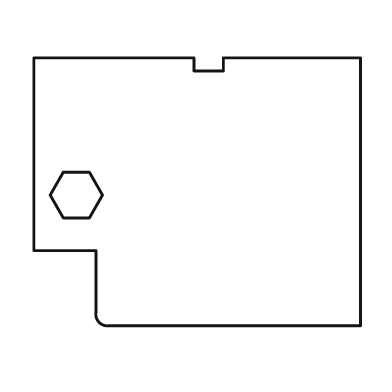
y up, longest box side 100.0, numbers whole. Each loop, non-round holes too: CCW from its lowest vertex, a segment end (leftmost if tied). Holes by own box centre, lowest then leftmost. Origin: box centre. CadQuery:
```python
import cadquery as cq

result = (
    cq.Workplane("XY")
    .moveTo(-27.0, -41.0)
    .lineTo(50.0, -41.0)
    .lineTo(50.0, 41.0)
    .lineTo(8.0, 41.0)
    .lineTo(8.0, 37.0)
    .lineTo(-1.0, 37.0)
    .lineTo(-1.0, 41.0)
    .lineTo(-50.0, 41.0)
    .lineTo(-50.0, -18.0)
    .lineTo(-31.0, -18.0)
    .lineTo(-31.0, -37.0)
    .threePointArc((-30.0, -40.0), (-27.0, -41.0))
    .close()
    .moveTo(-41.0, -8.0)
    .lineTo(-33.0, -8.0)
    .lineTo(-29.0, -1.0)
    .lineTo(-33.0, 6.0)
    .lineTo(-41.0, 6.0)
    .lineTo(-45.0, -1.0)
    .close()
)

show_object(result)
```